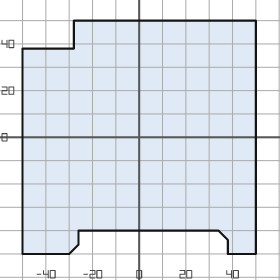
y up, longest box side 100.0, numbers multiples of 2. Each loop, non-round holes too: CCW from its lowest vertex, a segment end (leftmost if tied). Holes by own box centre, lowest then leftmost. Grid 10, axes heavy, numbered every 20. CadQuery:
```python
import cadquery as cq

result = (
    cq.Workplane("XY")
    .moveTo(-50.0, -50.0)
    .lineTo(-30.0, -50.0)
    .lineTo(-26.0, -46.0)
    .lineTo(-26.0, -40.0)
    .lineTo(34.0, -40.0)
    .lineTo(38.0, -44.0)
    .lineTo(38.0, -50.0)
    .lineTo(50.0, -50.0)
    .lineTo(50.0, 50.0)
    .lineTo(-28.0, 50.0)
    .lineTo(-28.0, 38.0)
    .lineTo(-50.0, 38.0)
    .close()
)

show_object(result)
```